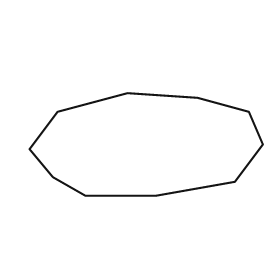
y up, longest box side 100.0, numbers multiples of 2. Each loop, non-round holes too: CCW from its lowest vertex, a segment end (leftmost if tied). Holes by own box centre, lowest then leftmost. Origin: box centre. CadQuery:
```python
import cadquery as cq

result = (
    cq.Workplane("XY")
    .moveTo(-26.0, -22.0)
    .lineTo(4.0, -22.0)
    .lineTo(38.0, -16.0)
    .lineTo(50.0, 0.0)
    .lineTo(44.0, 14.0)
    .lineTo(22.0, 20.0)
    .lineTo(-8.0, 22.0)
    .lineTo(-38.0, 14.0)
    .lineTo(-50.0, -2.0)
    .lineTo(-40.0, -14.0)
    .close()
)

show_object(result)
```